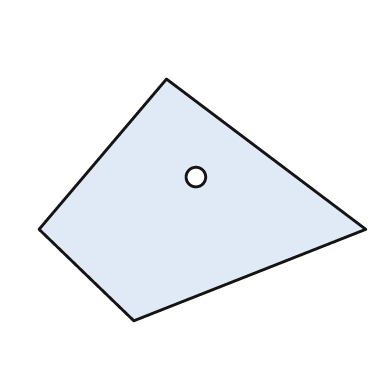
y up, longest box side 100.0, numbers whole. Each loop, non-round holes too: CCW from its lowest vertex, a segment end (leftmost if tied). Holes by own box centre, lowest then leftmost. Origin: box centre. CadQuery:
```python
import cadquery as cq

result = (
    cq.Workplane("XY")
    .moveTo(-21.0, -37.0)
    .lineTo(50.0, -9.0)
    .lineTo(-11.0, 37.0)
    .lineTo(-50.0, -9.0)
    .close()
    .moveTo(-2.0, 7.0)
    .circle(3.0)
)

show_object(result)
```